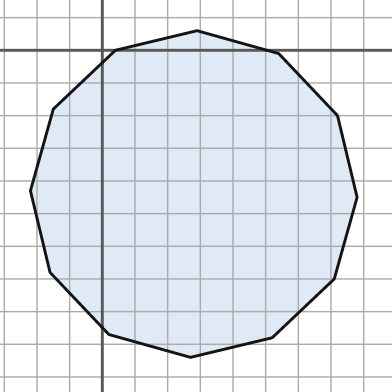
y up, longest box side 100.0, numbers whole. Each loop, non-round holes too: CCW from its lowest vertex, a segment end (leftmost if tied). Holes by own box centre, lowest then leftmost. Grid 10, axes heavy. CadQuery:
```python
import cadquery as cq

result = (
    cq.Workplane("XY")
    .moveTo(27.0, -94.0)
    .lineTo(52.0, -88.0)
    .lineTo(71.0, -70.0)
    .lineTo(78.0, -45.0)
    .lineTo(72.0, -20.0)
    .lineTo(54.0, -1.0)
    .lineTo(29.0, 6.0)
    .lineTo(4.0, 0.0)
    .lineTo(-15.0, -18.0)
    .lineTo(-22.0, -43.0)
    .lineTo(-16.0, -68.0)
    .lineTo(2.0, -87.0)
    .close()
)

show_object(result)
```